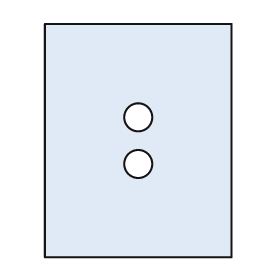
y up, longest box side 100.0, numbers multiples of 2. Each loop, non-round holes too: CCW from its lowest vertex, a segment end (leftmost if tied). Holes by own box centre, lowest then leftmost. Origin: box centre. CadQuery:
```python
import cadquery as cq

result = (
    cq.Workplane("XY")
    .moveTo(-40.0, -50.0)
    .lineTo(40.0, -50.0)
    .lineTo(40.0, 50.0)
    .lineTo(-40.0, 50.0)
    .close()
    .moveTo(0.0, -10.0)
    .circle(6.0)
    .moveTo(0.0, 10.0)
    .circle(6.0)
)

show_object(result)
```